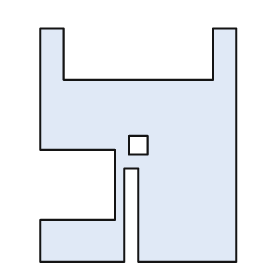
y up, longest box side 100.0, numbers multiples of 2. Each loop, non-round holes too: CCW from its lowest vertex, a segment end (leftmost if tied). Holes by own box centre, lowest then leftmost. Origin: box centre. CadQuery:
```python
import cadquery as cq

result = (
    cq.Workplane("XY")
    .moveTo(-42.0, -50.0)
    .lineTo(-6.0, -50.0)
    .lineTo(-6.0, -10.0)
    .lineTo(0.0, -10.0)
    .lineTo(0.0, -50.0)
    .lineTo(42.0, -50.0)
    .lineTo(42.0, 50.0)
    .lineTo(32.0, 50.0)
    .lineTo(32.0, 28.0)
    .lineTo(-32.0, 28.0)
    .lineTo(-32.0, 50.0)
    .lineTo(-42.0, 50.0)
    .lineTo(-42.0, -2.0)
    .lineTo(-10.0, -2.0)
    .lineTo(-10.0, -32.0)
    .lineTo(-42.0, -32.0)
    .close()
    .moveTo(-4.0, -4.0)
    .lineTo(4.0, -4.0)
    .lineTo(4.0, 4.0)
    .lineTo(-4.0, 4.0)
    .close()
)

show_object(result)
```